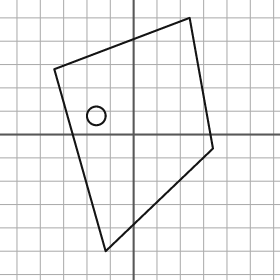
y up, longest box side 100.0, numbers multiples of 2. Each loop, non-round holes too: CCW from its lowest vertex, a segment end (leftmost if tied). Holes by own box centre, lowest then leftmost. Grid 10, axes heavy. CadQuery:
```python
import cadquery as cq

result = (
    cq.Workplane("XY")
    .moveTo(-12.0, -50.0)
    .lineTo(34.0, -6.0)
    .lineTo(24.0, 50.0)
    .lineTo(-34.0, 28.0)
    .close()
    .moveTo(-16.0, 8.0)
    .circle(4.0)
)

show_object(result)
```